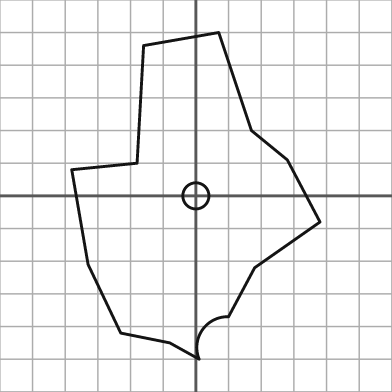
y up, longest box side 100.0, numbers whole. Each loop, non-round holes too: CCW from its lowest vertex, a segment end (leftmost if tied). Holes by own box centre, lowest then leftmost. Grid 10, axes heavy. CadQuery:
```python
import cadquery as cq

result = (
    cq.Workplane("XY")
    .moveTo(1.0, -50.0)
    .threePointArc((2.0, -41.0), (10.0, -37.0))
    .lineTo(18.0, -22.0)
    .lineTo(38.0, -8.0)
    .lineTo(28.0, 11.0)
    .lineTo(17.0, 20.0)
    .lineTo(7.0, 50.0)
    .lineTo(-16.0, 46.0)
    .lineTo(-18.0, 10.0)
    .lineTo(-38.0, 8.0)
    .lineTo(-33.0, -21.0)
    .lineTo(-23.0, -42.0)
    .lineTo(-8.0, -45.0)
    .close()
    .moveTo(0.0, 0.0)
    .circle(4.0)
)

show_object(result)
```